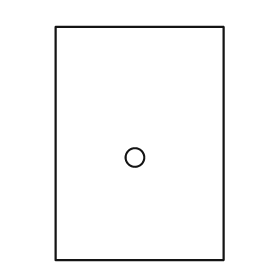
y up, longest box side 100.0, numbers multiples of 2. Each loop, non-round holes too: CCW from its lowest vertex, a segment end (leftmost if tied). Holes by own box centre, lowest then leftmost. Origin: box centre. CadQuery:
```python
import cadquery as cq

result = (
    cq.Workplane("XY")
    .moveTo(-36.0, -50.0)
    .lineTo(36.0, -50.0)
    .lineTo(36.0, 50.0)
    .lineTo(-36.0, 50.0)
    .close()
    .moveTo(-2.0, -6.0)
    .circle(4.0)
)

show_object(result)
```